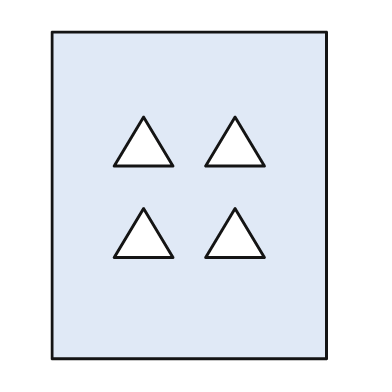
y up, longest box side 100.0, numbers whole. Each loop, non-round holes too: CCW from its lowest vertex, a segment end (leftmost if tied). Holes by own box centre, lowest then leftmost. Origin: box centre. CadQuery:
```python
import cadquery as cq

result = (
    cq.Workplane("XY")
    .moveTo(-42.0, -50.0)
    .lineTo(42.0, -50.0)
    .lineTo(42.0, 50.0)
    .lineTo(-42.0, 50.0)
    .close()
    .moveTo(-23.0, -19.0)
    .lineTo(-5.0, -19.0)
    .lineTo(-14.0, -4.0)
    .close()
    .moveTo(5.0, -19.0)
    .lineTo(23.0, -19.0)
    .lineTo(14.0, -4.0)
    .close()
    .moveTo(-23.0, 9.0)
    .lineTo(-5.0, 9.0)
    .lineTo(-14.0, 24.0)
    .close()
    .moveTo(5.0, 9.0)
    .lineTo(23.0, 9.0)
    .lineTo(14.0, 24.0)
    .close()
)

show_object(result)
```